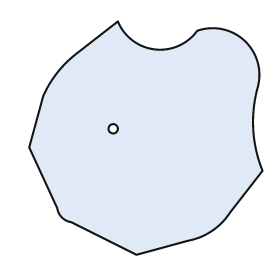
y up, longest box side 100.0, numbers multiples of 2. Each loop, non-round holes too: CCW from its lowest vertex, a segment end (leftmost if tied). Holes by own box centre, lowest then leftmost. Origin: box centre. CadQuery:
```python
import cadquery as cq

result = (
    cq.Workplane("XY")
    .moveTo(-4.0, -50.0)
    .lineTo(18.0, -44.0)
    .threePointArc((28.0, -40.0), (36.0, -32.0))
    .lineTo(50.0, -14.0)
    .threePointArc((46.0, 4.0), (48.0, 22.0))
    .threePointArc((42.0, 42.0), (22.0, 46.0))
    .threePointArc((4.0, 38.0), (-12.0, 50.0))
    .lineTo(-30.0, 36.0)
    .threePointArc((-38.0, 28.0), (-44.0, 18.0))
    .lineTo(-50.0, -4.0)
    .lineTo(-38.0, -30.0)
    .threePointArc((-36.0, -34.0), (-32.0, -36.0))
    .close()
    .moveTo(-14.0, 4.0)
    .circle(2.0)
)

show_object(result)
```